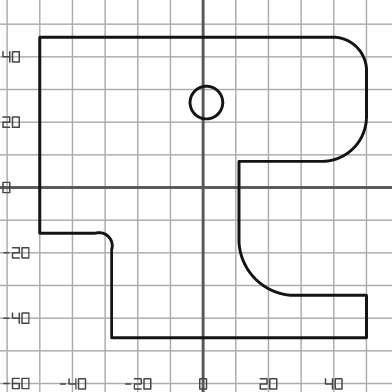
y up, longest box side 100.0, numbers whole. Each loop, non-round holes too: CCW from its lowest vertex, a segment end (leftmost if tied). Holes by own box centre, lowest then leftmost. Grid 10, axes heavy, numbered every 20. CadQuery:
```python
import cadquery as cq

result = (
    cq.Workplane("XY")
    .moveTo(-28.0, -46.0)
    .lineTo(50.0, -46.0)
    .lineTo(50.0, -33.0)
    .lineTo(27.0, -33.0)
    .threePointArc((16.0, -28.0), (11.0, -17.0))
    .lineTo(11.0, 8.0)
    .lineTo(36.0, 8.0)
    .threePointArc((46.0, 12.0), (50.0, 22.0))
    .lineTo(50.0, 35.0)
    .threePointArc((47.0, 43.0), (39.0, 46.0))
    .lineTo(-50.0, 46.0)
    .lineTo(-50.0, -14.0)
    .lineTo(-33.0, -14.0)
    .threePointArc((-29.0, -15.0), (-28.0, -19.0))
    .close()
    .moveTo(1.0, 26.0)
    .circle(5.0)
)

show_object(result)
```